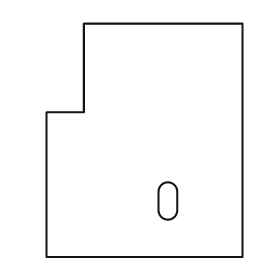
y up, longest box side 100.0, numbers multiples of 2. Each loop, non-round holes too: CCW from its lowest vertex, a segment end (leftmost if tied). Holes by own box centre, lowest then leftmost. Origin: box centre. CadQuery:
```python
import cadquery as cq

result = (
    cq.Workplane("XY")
    .moveTo(-42.0, -50.0)
    .lineTo(42.0, -50.0)
    .lineTo(42.0, 50.0)
    .lineTo(-26.0, 50.0)
    .lineTo(-26.0, 12.0)
    .lineTo(-42.0, 12.0)
    .close()
    .moveTo(6.0, -30.0)
    .threePointArc((10.0, -34.0), (14.0, -30.0))
    .lineTo(14.0, -22.0)
    .threePointArc((10.0, -18.0), (6.0, -22.0))
    .close()
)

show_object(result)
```